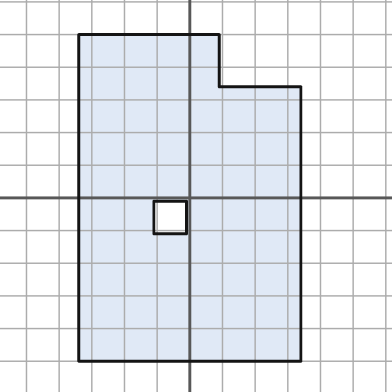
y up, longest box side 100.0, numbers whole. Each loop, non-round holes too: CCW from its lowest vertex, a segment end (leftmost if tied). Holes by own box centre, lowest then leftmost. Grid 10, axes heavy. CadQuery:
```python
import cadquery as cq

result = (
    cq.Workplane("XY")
    .moveTo(-34.0, -50.0)
    .lineTo(34.0, -50.0)
    .lineTo(34.0, 34.0)
    .lineTo(9.0, 34.0)
    .lineTo(9.0, 50.0)
    .lineTo(-34.0, 50.0)
    .close()
    .moveTo(-11.0, -11.0)
    .lineTo(-1.0, -11.0)
    .lineTo(-1.0, -1.0)
    .lineTo(-11.0, -1.0)
    .close()
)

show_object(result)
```